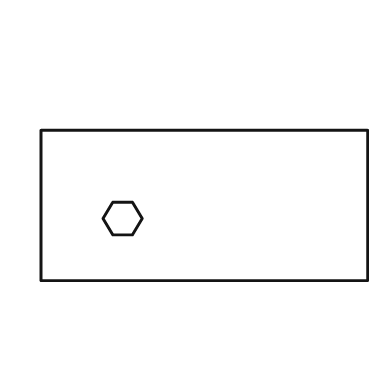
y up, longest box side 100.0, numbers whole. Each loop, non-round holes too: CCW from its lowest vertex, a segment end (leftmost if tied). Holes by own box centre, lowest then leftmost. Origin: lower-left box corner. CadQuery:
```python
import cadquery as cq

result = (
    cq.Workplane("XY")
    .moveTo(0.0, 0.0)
    .lineTo(100.0, 0.0)
    .lineTo(100.0, 46.0)
    .lineTo(0.0, 46.0)
    .close()
    .moveTo(22.0, 14.0)
    .lineTo(28.0, 14.0)
    .lineTo(31.0, 19.0)
    .lineTo(28.0, 24.0)
    .lineTo(22.0, 24.0)
    .lineTo(19.0, 19.0)
    .close()
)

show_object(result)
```